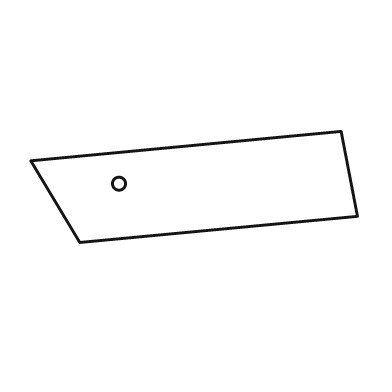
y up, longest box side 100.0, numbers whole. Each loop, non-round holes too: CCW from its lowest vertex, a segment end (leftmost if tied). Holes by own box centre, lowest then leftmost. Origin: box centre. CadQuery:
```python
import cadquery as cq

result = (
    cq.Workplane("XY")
    .moveTo(-35.0, -17.0)
    .lineTo(50.0, -9.0)
    .lineTo(45.0, 17.0)
    .lineTo(-50.0, 8.0)
    .close()
    .moveTo(-23.0, 1.0)
    .circle(2.0)
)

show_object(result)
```